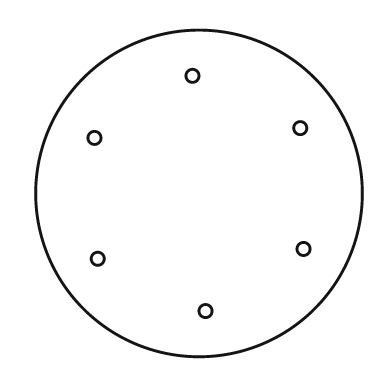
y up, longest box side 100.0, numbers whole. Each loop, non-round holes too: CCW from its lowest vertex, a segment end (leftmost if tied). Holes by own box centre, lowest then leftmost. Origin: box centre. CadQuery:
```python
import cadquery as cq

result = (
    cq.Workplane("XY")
    .moveTo(0.0, 0.0)
    .circle(50.0)
    .moveTo(2.0, -36.0)
    .circle(2.0)
    .moveTo(-31.0, -20.0)
    .circle(2.0)
    .moveTo(32.0, -17.0)
    .circle(2.0)
    .moveTo(-32.0, 17.0)
    .circle(2.0)
    .moveTo(31.0, 20.0)
    .circle(2.0)
    .moveTo(-2.0, 36.0)
    .circle(2.0)
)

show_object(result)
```